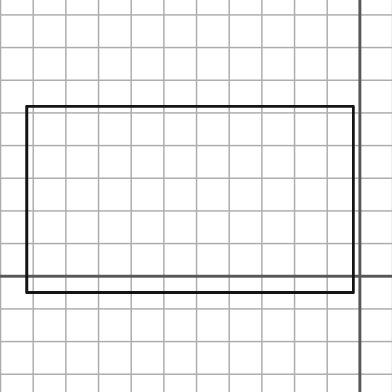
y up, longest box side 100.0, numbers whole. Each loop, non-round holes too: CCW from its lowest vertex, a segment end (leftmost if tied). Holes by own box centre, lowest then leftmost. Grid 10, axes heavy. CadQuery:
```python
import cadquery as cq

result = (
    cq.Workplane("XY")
    .moveTo(-102.0, -5.0)
    .lineTo(-2.0, -5.0)
    .lineTo(-2.0, 52.0)
    .lineTo(-102.0, 52.0)
    .close()
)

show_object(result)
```